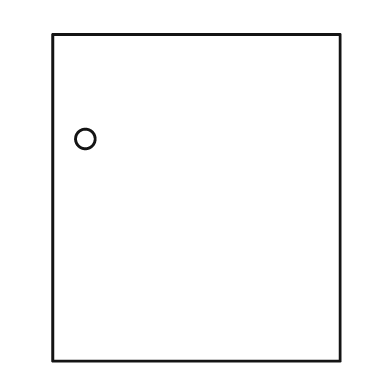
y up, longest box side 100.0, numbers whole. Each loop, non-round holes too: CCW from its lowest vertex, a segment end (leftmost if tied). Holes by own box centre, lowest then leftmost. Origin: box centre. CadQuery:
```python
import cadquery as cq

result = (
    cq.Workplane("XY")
    .moveTo(-44.0, -50.0)
    .lineTo(44.0, -50.0)
    .lineTo(44.0, 50.0)
    .lineTo(-44.0, 50.0)
    .close()
    .moveTo(-34.0, 18.0)
    .circle(3.0)
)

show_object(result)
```